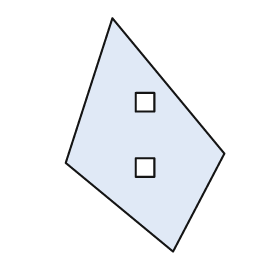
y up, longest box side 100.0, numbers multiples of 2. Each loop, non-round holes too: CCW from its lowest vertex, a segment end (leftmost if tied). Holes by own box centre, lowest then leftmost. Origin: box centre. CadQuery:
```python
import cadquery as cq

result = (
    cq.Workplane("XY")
    .moveTo(12.0, -50.0)
    .lineTo(34.0, -8.0)
    .lineTo(-14.0, 50.0)
    .lineTo(-34.0, -12.0)
    .close()
    .moveTo(-4.0, -18.0)
    .lineTo(4.0, -18.0)
    .lineTo(4.0, -10.0)
    .lineTo(-4.0, -10.0)
    .close()
    .moveTo(-4.0, 10.0)
    .lineTo(4.0, 10.0)
    .lineTo(4.0, 18.0)
    .lineTo(-4.0, 18.0)
    .close()
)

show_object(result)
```